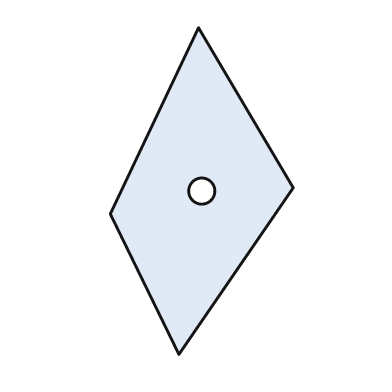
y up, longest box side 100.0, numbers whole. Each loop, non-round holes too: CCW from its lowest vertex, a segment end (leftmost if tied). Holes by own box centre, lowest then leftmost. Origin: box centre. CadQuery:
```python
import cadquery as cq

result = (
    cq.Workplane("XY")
    .moveTo(-7.0, -50.0)
    .lineTo(28.0, 1.0)
    .lineTo(-1.0, 50.0)
    .lineTo(-28.0, -7.0)
    .close()
    .moveTo(0.0, 0.0)
    .circle(4.0)
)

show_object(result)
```